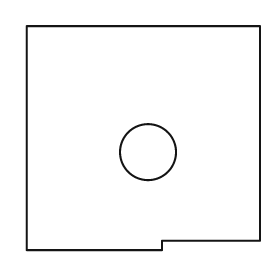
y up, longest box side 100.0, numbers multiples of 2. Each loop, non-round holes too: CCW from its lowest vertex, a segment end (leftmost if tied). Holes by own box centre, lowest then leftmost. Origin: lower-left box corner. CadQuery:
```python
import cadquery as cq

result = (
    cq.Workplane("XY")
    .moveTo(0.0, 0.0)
    .lineTo(58.0, 0.0)
    .lineTo(58.0, 4.0)
    .lineTo(100.0, 4.0)
    .lineTo(100.0, 96.0)
    .lineTo(0.0, 96.0)
    .close()
    .moveTo(52.0, 42.0)
    .circle(12.0)
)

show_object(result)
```